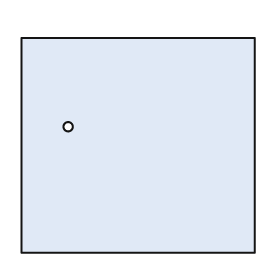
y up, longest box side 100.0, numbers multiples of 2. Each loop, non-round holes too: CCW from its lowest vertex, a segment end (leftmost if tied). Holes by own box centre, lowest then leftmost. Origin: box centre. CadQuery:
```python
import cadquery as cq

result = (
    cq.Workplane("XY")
    .moveTo(-50.0, -46.0)
    .lineTo(50.0, -46.0)
    .lineTo(50.0, 46.0)
    .lineTo(-50.0, 46.0)
    .close()
    .moveTo(-30.0, 8.0)
    .circle(2.0)
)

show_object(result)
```